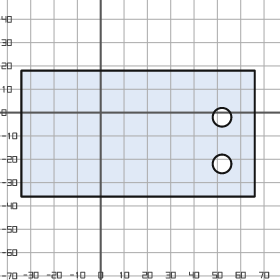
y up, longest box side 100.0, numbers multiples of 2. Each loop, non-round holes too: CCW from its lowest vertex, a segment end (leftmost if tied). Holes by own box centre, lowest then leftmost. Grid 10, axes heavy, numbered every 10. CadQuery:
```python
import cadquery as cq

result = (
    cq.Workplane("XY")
    .moveTo(-34.0, -36.0)
    .lineTo(66.0, -36.0)
    .lineTo(66.0, 18.0)
    .lineTo(-34.0, 18.0)
    .close()
    .moveTo(52.0, -22.0)
    .circle(4.0)
    .moveTo(52.0, -2.0)
    .circle(4.0)
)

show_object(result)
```